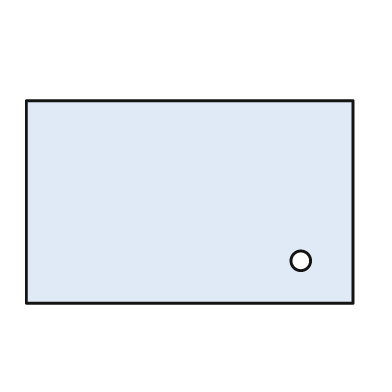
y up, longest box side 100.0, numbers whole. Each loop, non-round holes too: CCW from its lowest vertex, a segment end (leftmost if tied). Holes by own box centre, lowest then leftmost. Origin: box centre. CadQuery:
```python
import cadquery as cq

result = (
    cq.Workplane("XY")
    .moveTo(-50.0, -31.0)
    .lineTo(50.0, -31.0)
    .lineTo(50.0, 31.0)
    .lineTo(-50.0, 31.0)
    .close()
    .moveTo(34.0, -18.0)
    .circle(3.0)
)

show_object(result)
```